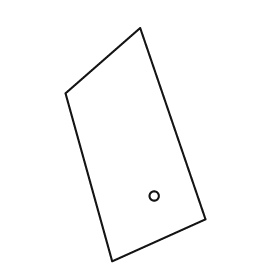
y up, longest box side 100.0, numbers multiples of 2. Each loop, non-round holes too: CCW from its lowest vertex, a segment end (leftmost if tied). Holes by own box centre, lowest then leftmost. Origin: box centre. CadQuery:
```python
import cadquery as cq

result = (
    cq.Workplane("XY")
    .moveTo(-10.0, -50.0)
    .lineTo(30.0, -32.0)
    .lineTo(2.0, 50.0)
    .lineTo(-30.0, 22.0)
    .close()
    .moveTo(8.0, -22.0)
    .circle(2.0)
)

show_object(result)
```